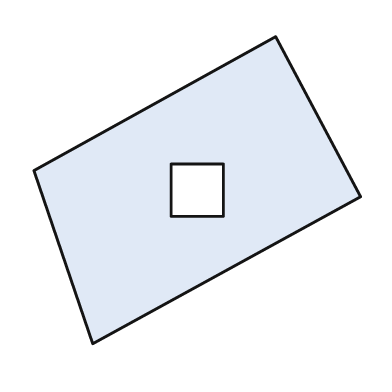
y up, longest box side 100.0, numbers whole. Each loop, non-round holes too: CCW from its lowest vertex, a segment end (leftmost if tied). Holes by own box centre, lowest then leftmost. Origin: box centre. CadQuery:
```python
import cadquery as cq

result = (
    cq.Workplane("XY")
    .moveTo(-32.0, -47.0)
    .lineTo(50.0, -2.0)
    .lineTo(24.0, 47.0)
    .lineTo(-50.0, 6.0)
    .close()
    .moveTo(-8.0, -8.0)
    .lineTo(8.0, -8.0)
    .lineTo(8.0, 8.0)
    .lineTo(-8.0, 8.0)
    .close()
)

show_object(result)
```